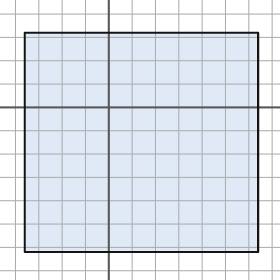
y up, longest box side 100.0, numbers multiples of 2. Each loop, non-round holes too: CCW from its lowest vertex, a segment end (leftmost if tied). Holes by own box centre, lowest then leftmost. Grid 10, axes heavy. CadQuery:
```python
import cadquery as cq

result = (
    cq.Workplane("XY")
    .moveTo(-36.0, -62.0)
    .lineTo(64.0, -62.0)
    .lineTo(64.0, 32.0)
    .lineTo(-36.0, 32.0)
    .close()
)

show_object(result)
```